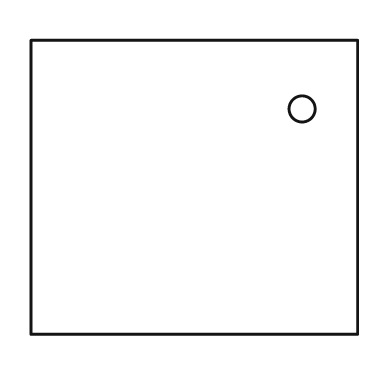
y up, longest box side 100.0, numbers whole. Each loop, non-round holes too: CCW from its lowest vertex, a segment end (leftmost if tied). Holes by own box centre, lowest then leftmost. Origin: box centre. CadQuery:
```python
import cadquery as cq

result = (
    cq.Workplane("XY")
    .moveTo(-50.0, -45.0)
    .lineTo(50.0, -45.0)
    .lineTo(50.0, 45.0)
    .lineTo(-50.0, 45.0)
    .close()
    .moveTo(33.0, 24.0)
    .circle(4.0)
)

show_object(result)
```